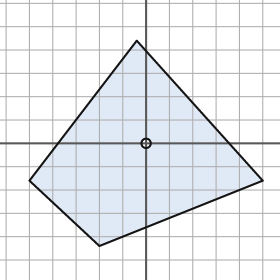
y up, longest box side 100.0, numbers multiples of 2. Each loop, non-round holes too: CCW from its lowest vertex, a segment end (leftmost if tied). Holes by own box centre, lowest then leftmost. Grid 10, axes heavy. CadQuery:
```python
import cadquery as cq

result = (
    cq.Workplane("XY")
    .moveTo(-20.0, -44.0)
    .lineTo(50.0, -16.0)
    .lineTo(-4.0, 44.0)
    .lineTo(-50.0, -16.0)
    .close()
    .moveTo(0.0, 0.0)
    .circle(2.0)
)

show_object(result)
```